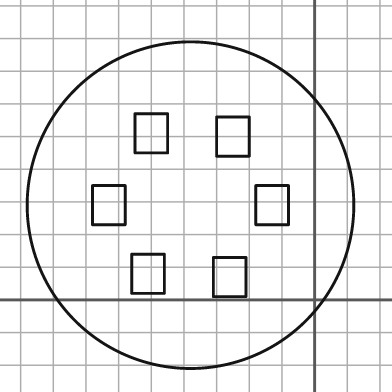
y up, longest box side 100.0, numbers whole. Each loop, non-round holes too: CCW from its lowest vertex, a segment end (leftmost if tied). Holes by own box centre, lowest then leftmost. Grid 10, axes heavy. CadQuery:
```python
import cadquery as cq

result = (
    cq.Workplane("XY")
    .moveTo(-38.0, 29.0)
    .circle(50.0)
    .moveTo(-31.0, 1.0)
    .lineTo(-21.0, 1.0)
    .lineTo(-21.0, 13.0)
    .lineTo(-31.0, 13.0)
    .close()
    .moveTo(-56.0, 2.0)
    .lineTo(-46.0, 2.0)
    .lineTo(-46.0, 14.0)
    .lineTo(-56.0, 14.0)
    .close()
    .moveTo(-68.0, 23.0)
    .lineTo(-58.0, 23.0)
    .lineTo(-58.0, 35.0)
    .lineTo(-68.0, 35.0)
    .close()
    .moveTo(-18.0, 23.0)
    .lineTo(-8.0, 23.0)
    .lineTo(-8.0, 35.0)
    .lineTo(-18.0, 35.0)
    .close()
    .moveTo(-30.0, 44.0)
    .lineTo(-20.0, 44.0)
    .lineTo(-20.0, 56.0)
    .lineTo(-30.0, 56.0)
    .close()
    .moveTo(-55.0, 45.0)
    .lineTo(-45.0, 45.0)
    .lineTo(-45.0, 57.0)
    .lineTo(-55.0, 57.0)
    .close()
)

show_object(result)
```